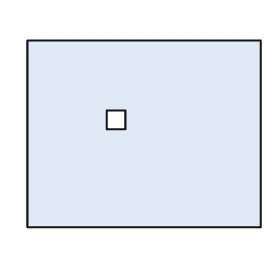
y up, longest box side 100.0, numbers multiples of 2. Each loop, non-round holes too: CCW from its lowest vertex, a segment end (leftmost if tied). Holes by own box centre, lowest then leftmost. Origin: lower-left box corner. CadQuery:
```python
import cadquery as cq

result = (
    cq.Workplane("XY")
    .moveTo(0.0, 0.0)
    .lineTo(100.0, 0.0)
    .lineTo(100.0, 80.0)
    .lineTo(0.0, 80.0)
    .close()
    .moveTo(34.0, 42.0)
    .lineTo(42.0, 42.0)
    .lineTo(42.0, 50.0)
    .lineTo(34.0, 50.0)
    .close()
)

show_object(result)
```